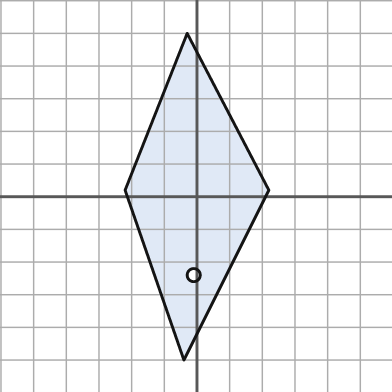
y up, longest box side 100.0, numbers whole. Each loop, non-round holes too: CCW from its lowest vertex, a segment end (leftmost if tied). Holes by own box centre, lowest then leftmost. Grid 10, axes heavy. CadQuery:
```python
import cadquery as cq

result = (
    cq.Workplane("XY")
    .moveTo(-4.0, -50.0)
    .lineTo(22.0, 2.0)
    .lineTo(-3.0, 50.0)
    .lineTo(-22.0, 2.0)
    .close()
    .moveTo(-1.0, -24.0)
    .circle(2.0)
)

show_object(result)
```